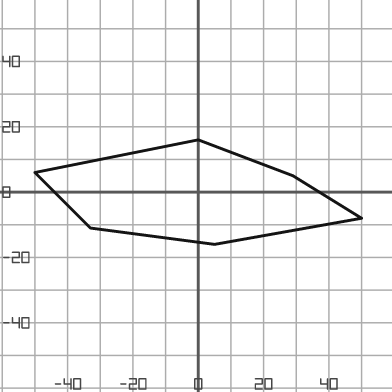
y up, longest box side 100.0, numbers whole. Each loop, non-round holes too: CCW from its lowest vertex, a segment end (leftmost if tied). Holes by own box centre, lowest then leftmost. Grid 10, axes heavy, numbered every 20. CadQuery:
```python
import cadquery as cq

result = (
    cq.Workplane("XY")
    .moveTo(5.0, -16.0)
    .lineTo(50.0, -8.0)
    .lineTo(29.0, 5.0)
    .lineTo(0.0, 16.0)
    .lineTo(-50.0, 6.0)
    .lineTo(-33.0, -11.0)
    .close()
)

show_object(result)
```